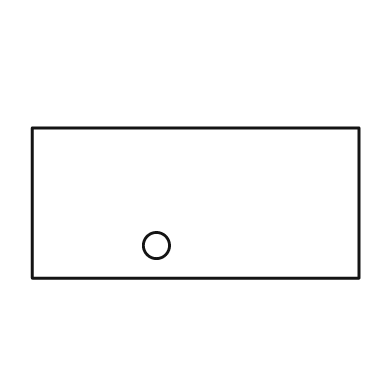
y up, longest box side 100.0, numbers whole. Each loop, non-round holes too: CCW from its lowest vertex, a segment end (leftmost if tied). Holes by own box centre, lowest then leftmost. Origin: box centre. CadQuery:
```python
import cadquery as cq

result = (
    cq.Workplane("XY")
    .moveTo(-50.0, -23.0)
    .lineTo(50.0, -23.0)
    .lineTo(50.0, 23.0)
    .lineTo(-50.0, 23.0)
    .close()
    .moveTo(-12.0, -13.0)
    .circle(4.0)
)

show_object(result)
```